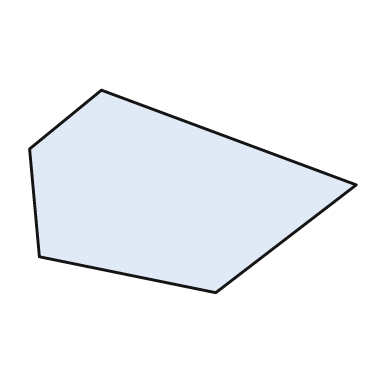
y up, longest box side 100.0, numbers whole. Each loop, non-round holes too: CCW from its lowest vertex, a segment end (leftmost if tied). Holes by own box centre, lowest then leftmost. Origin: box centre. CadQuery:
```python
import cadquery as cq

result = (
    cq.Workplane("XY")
    .moveTo(7.0, -31.0)
    .lineTo(50.0, 2.0)
    .lineTo(-28.0, 31.0)
    .lineTo(-50.0, 13.0)
    .lineTo(-47.0, -20.0)
    .close()
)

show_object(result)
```